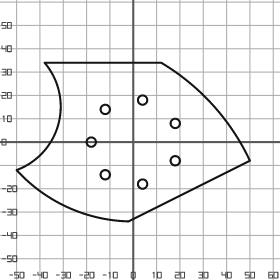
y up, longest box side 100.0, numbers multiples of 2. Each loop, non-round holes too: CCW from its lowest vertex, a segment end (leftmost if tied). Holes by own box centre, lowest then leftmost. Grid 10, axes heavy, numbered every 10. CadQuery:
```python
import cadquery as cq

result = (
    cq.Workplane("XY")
    .moveTo(-2.0, -34.0)
    .lineTo(50.0, -8.0)
    .threePointArc((34.0, 16.0), (12.0, 34.0))
    .lineTo(-38.0, 34.0)
    .threePointArc((-32.0, 8.0), (-50.0, -12.0))
    .threePointArc((-28.0, -28.0), (-2.0, -34.0))
    .close()
    .moveTo(4.0, -18.0)
    .circle(2.0)
    .moveTo(-12.0, -14.0)
    .circle(2.0)
    .moveTo(18.0, -8.0)
    .circle(2.0)
    .moveTo(-18.0, 0.0)
    .circle(2.0)
    .moveTo(18.0, 8.0)
    .circle(2.0)
    .moveTo(-12.0, 14.0)
    .circle(2.0)
    .moveTo(4.0, 18.0)
    .circle(2.0)
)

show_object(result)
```